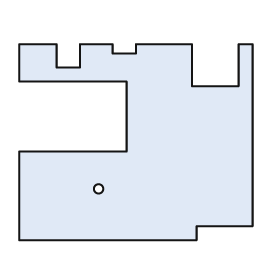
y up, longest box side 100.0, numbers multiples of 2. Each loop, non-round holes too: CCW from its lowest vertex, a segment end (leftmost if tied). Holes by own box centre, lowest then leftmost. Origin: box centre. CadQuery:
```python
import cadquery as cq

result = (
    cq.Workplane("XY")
    .moveTo(-50.0, -42.0)
    .lineTo(26.0, -42.0)
    .lineTo(26.0, -36.0)
    .lineTo(50.0, -36.0)
    .lineTo(50.0, 42.0)
    .lineTo(44.0, 42.0)
    .lineTo(44.0, 24.0)
    .lineTo(24.0, 24.0)
    .lineTo(24.0, 42.0)
    .lineTo(0.0, 42.0)
    .lineTo(0.0, 38.0)
    .lineTo(-10.0, 38.0)
    .lineTo(-10.0, 42.0)
    .lineTo(-24.0, 42.0)
    .lineTo(-24.0, 32.0)
    .lineTo(-34.0, 32.0)
    .lineTo(-34.0, 42.0)
    .lineTo(-50.0, 42.0)
    .lineTo(-50.0, 26.0)
    .lineTo(-4.0, 26.0)
    .lineTo(-4.0, -4.0)
    .lineTo(-50.0, -4.0)
    .close()
    .moveTo(-16.0, -20.0)
    .circle(2.0)
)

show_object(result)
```